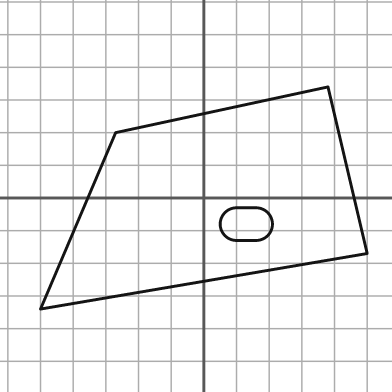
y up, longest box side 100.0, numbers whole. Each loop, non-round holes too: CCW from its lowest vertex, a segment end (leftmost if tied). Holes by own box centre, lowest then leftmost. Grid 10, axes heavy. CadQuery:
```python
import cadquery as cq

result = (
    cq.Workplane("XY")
    .moveTo(-50.0, -34.0)
    .lineTo(50.0, -17.0)
    .lineTo(38.0, 34.0)
    .lineTo(-27.0, 20.0)
    .close()
    .moveTo(10.0, -13.0)
    .lineTo(16.0, -13.0)
    .threePointArc((21.0, -8.0), (16.0, -3.0))
    .lineTo(10.0, -3.0)
    .threePointArc((5.0, -8.0), (10.0, -13.0))
    .close()
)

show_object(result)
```